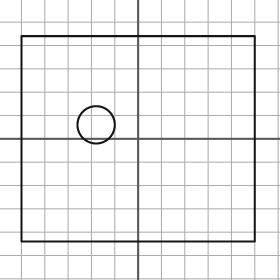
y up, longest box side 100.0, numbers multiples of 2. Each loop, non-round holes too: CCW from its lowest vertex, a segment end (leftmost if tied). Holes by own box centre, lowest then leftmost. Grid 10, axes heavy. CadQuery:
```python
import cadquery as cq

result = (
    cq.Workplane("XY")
    .moveTo(-50.0, -44.0)
    .lineTo(50.0, -44.0)
    .lineTo(50.0, 44.0)
    .lineTo(-50.0, 44.0)
    .close()
    .moveTo(-18.0, 6.0)
    .circle(8.0)
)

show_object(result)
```